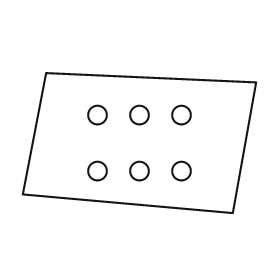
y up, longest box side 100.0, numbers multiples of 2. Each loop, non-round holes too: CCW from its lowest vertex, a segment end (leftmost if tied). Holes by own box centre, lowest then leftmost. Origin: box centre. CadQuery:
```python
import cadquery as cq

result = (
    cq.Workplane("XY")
    .moveTo(40.0, -30.0)
    .lineTo(50.0, 26.0)
    .lineTo(-40.0, 30.0)
    .lineTo(-50.0, -22.0)
    .close()
    .moveTo(-18.0, -12.0)
    .circle(4.0)
    .moveTo(0.0, -12.0)
    .circle(4.0)
    .moveTo(18.0, -12.0)
    .circle(4.0)
    .moveTo(-18.0, 12.0)
    .circle(4.0)
    .moveTo(0.0, 12.0)
    .circle(4.0)
    .moveTo(18.0, 12.0)
    .circle(4.0)
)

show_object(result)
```